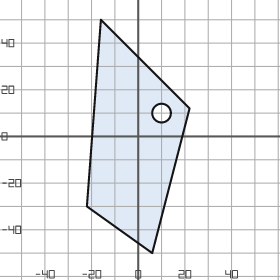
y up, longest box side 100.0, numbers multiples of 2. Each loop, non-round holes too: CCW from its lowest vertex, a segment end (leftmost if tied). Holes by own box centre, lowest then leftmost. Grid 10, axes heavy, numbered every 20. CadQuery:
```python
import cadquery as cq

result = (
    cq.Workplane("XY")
    .moveTo(6.0, -50.0)
    .lineTo(22.0, 12.0)
    .lineTo(-16.0, 50.0)
    .lineTo(-22.0, -30.0)
    .close()
    .moveTo(10.0, 10.0)
    .circle(4.0)
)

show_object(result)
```